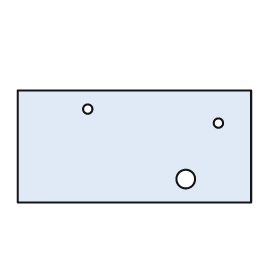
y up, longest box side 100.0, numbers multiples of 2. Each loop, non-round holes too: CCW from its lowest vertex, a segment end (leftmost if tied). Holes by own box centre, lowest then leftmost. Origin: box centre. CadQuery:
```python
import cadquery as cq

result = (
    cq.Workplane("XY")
    .moveTo(-50.0, -24.0)
    .lineTo(50.0, -24.0)
    .lineTo(50.0, 24.0)
    .lineTo(-50.0, 24.0)
    .close()
    .moveTo(22.0, -14.0)
    .circle(4.0)
    .moveTo(36.0, 10.0)
    .circle(2.0)
    .moveTo(-20.0, 16.0)
    .circle(2.0)
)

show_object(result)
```